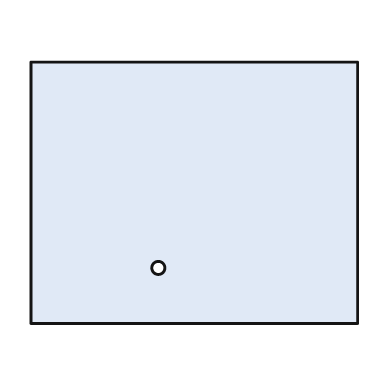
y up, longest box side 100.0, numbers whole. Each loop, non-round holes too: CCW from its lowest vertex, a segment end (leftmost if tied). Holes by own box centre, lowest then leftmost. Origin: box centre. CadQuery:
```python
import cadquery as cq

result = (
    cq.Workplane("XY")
    .moveTo(-50.0, -40.0)
    .lineTo(50.0, -40.0)
    .lineTo(50.0, 40.0)
    .lineTo(-50.0, 40.0)
    .close()
    .moveTo(-11.0, -23.0)
    .circle(2.0)
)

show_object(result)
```